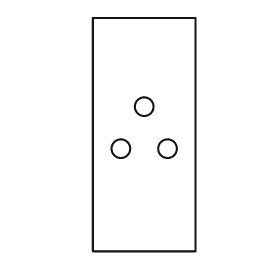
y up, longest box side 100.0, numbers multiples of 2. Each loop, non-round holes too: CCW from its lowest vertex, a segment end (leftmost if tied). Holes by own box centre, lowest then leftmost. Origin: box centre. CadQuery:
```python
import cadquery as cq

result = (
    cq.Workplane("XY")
    .moveTo(-22.0, -50.0)
    .lineTo(22.0, -50.0)
    .lineTo(22.0, 50.0)
    .lineTo(-22.0, 50.0)
    .close()
    .moveTo(-10.0, -6.0)
    .circle(4.0)
    .moveTo(10.0, -6.0)
    .circle(4.0)
    .moveTo(0.0, 12.0)
    .circle(4.0)
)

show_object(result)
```